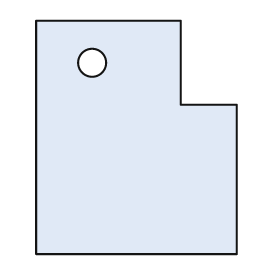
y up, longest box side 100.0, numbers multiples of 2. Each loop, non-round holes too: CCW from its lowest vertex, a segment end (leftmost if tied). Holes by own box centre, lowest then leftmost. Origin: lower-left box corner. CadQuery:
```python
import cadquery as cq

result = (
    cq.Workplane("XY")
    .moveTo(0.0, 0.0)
    .lineTo(86.0, 0.0)
    .lineTo(86.0, 64.0)
    .lineTo(62.0, 64.0)
    .lineTo(62.0, 100.0)
    .lineTo(0.0, 100.0)
    .close()
    .moveTo(24.0, 82.0)
    .circle(6.0)
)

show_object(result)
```